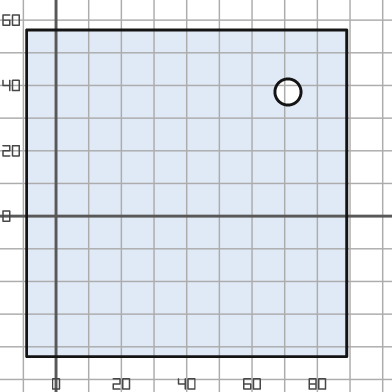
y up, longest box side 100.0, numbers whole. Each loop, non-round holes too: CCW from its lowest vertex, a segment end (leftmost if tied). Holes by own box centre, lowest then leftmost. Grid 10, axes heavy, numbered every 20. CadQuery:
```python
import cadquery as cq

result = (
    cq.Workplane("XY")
    .moveTo(-9.0, -43.0)
    .lineTo(89.0, -43.0)
    .lineTo(89.0, 57.0)
    .lineTo(-9.0, 57.0)
    .close()
    .moveTo(71.0, 38.0)
    .circle(4.0)
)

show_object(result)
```